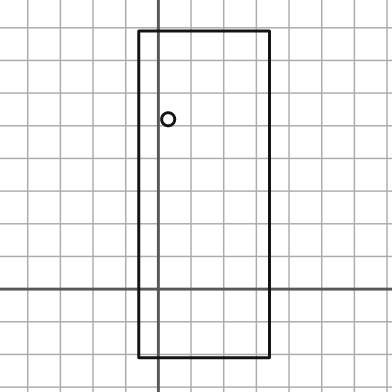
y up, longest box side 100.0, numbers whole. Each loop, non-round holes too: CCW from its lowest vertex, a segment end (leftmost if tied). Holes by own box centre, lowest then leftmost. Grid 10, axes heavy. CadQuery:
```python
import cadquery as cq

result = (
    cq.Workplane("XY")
    .moveTo(-6.0, -21.0)
    .lineTo(34.0, -21.0)
    .lineTo(34.0, 79.0)
    .lineTo(-6.0, 79.0)
    .close()
    .moveTo(3.0, 52.0)
    .circle(2.0)
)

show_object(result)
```